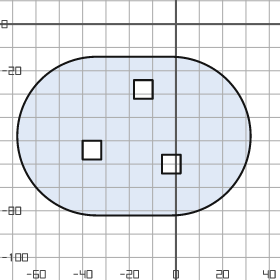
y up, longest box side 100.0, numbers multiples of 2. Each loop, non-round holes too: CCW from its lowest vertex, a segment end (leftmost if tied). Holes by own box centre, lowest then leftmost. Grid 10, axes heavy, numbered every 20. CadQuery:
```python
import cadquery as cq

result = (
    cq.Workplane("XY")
    .moveTo(-34.0, -82.0)
    .lineTo(-2.0, -82.0)
    .threePointArc((32.0, -48.0), (-2.0, -14.0))
    .lineTo(-34.0, -14.0)
    .threePointArc((-68.0, -48.0), (-34.0, -82.0))
    .close()
    .moveTo(-6.0, -64.0)
    .lineTo(2.0, -64.0)
    .lineTo(2.0, -56.0)
    .lineTo(-6.0, -56.0)
    .close()
    .moveTo(-40.0, -58.0)
    .lineTo(-32.0, -58.0)
    .lineTo(-32.0, -50.0)
    .lineTo(-40.0, -50.0)
    .close()
    .moveTo(-18.0, -32.0)
    .lineTo(-10.0, -32.0)
    .lineTo(-10.0, -24.0)
    .lineTo(-18.0, -24.0)
    .close()
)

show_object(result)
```